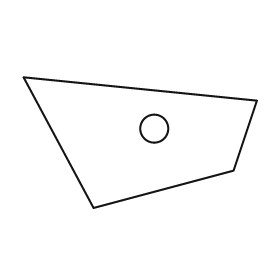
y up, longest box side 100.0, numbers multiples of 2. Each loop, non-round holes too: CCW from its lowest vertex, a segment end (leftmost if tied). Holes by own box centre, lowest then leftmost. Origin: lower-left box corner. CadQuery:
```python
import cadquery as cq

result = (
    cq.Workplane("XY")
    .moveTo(30.0, 0.0)
    .lineTo(90.0, 16.0)
    .lineTo(100.0, 46.0)
    .lineTo(0.0, 56.0)
    .close()
    .moveTo(56.0, 34.0)
    .circle(6.0)
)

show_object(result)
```